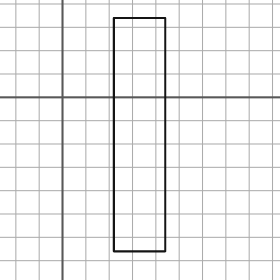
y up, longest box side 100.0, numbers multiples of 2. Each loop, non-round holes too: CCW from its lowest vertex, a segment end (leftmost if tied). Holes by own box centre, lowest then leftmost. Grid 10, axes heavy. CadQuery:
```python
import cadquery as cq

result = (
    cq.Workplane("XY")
    .moveTo(22.0, -66.0)
    .lineTo(44.0, -66.0)
    .lineTo(44.0, 34.0)
    .lineTo(22.0, 34.0)
    .close()
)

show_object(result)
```